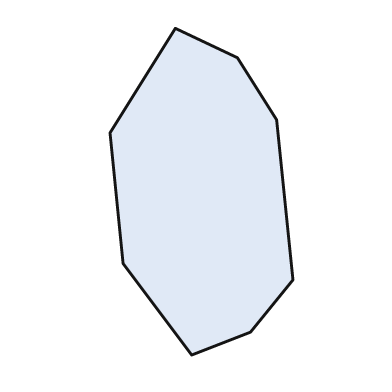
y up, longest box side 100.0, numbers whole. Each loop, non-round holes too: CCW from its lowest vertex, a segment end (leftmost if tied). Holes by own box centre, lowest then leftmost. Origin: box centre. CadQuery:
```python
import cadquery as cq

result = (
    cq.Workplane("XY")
    .moveTo(-3.0, -50.0)
    .lineTo(15.0, -43.0)
    .lineTo(28.0, -27.0)
    .lineTo(23.0, 22.0)
    .lineTo(11.0, 41.0)
    .lineTo(-8.0, 50.0)
    .lineTo(-28.0, 18.0)
    .lineTo(-24.0, -22.0)
    .close()
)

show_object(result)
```